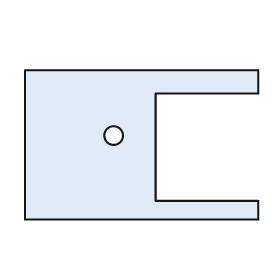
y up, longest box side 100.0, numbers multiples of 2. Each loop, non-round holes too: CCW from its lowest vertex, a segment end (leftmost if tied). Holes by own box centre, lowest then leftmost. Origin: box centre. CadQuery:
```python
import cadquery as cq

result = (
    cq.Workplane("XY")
    .moveTo(-50.0, -32.0)
    .lineTo(50.0, -32.0)
    .lineTo(50.0, -24.0)
    .lineTo(6.0, -24.0)
    .lineTo(6.0, 22.0)
    .lineTo(50.0, 22.0)
    .lineTo(50.0, 32.0)
    .lineTo(-50.0, 32.0)
    .close()
    .moveTo(-12.0, 4.0)
    .circle(4.0)
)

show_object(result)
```